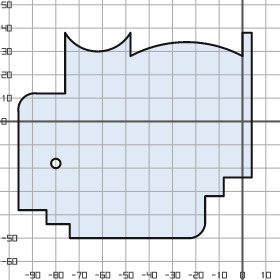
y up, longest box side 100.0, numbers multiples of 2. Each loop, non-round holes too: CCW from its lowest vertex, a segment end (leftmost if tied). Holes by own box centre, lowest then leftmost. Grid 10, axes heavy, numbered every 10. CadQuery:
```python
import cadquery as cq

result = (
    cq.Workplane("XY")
    .moveTo(-74.0, -50.0)
    .lineTo(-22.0, -50.0)
    .threePointArc((-18.0, -48.0), (-16.0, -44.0))
    .lineTo(-16.0, -32.0)
    .lineTo(-8.0, -32.0)
    .lineTo(-8.0, -24.0)
    .lineTo(4.0, -24.0)
    .lineTo(4.0, 38.0)
    .lineTo(0.0, 38.0)
    .lineTo(0.0, 28.0)
    .threePointArc((-24.0, 34.0), (-48.0, 28.0))
    .lineTo(-48.0, 38.0)
    .threePointArc((-62.0, 30.0), (-76.0, 38.0))
    .lineTo(-76.0, 12.0)
    .lineTo(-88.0, 12.0)
    .threePointArc((-94.0, 10.0), (-96.0, 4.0))
    .lineTo(-96.0, -38.0)
    .lineTo(-84.0, -38.0)
    .lineTo(-84.0, -44.0)
    .lineTo(-74.0, -44.0)
    .close()
    .moveTo(-80.0, -18.0)
    .circle(2.0)
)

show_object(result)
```